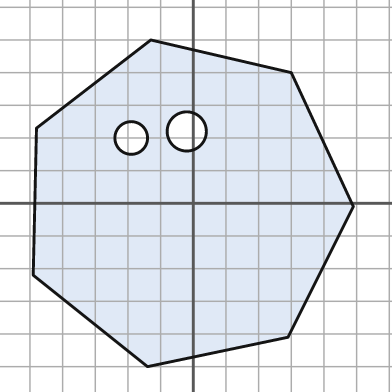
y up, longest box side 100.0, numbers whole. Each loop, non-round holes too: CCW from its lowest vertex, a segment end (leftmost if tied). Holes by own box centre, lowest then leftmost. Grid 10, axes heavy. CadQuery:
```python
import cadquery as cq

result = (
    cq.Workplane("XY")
    .moveTo(-14.0, -50.0)
    .lineTo(29.0, -41.0)
    .lineTo(49.0, -1.0)
    .lineTo(30.0, 40.0)
    .lineTo(-13.0, 50.0)
    .lineTo(-48.0, 23.0)
    .lineTo(-49.0, -22.0)
    .close()
    .moveTo(-19.0, 20.0)
    .circle(5.0)
    .moveTo(-2.0, 22.0)
    .circle(6.0)
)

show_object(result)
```